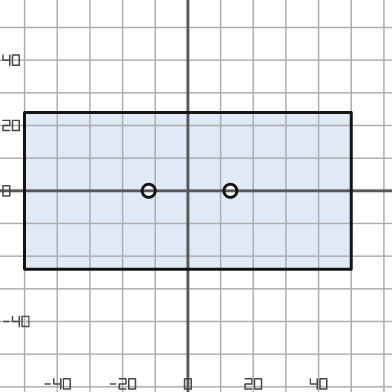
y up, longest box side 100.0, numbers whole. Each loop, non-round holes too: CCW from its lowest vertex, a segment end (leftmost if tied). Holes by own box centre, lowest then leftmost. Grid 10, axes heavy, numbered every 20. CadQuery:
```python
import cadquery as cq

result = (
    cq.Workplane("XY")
    .moveTo(-50.0, -24.0)
    .lineTo(50.0, -24.0)
    .lineTo(50.0, 24.0)
    .lineTo(-50.0, 24.0)
    .close()
    .moveTo(-12.0, 0.0)
    .circle(2.0)
    .moveTo(13.0, 0.0)
    .circle(2.0)
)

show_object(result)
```